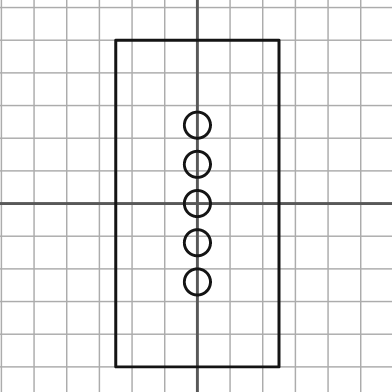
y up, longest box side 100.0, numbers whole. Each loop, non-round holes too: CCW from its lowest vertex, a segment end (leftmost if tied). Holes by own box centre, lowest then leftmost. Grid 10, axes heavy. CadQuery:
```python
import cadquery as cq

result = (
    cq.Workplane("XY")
    .moveTo(-25.0, -50.0)
    .lineTo(25.0, -50.0)
    .lineTo(25.0, 50.0)
    .lineTo(-25.0, 50.0)
    .close()
    .moveTo(0.0, -24.0)
    .circle(4.0)
    .moveTo(0.0, -12.0)
    .circle(4.0)
    .moveTo(0.0, 0.0)
    .circle(4.0)
    .moveTo(0.0, 12.0)
    .circle(4.0)
    .moveTo(0.0, 24.0)
    .circle(4.0)
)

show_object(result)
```